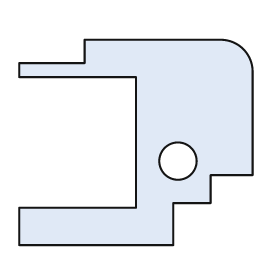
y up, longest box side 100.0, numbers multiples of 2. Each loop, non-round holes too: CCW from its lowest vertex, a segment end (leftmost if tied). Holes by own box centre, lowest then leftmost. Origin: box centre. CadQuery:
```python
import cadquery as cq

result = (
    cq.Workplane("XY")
    .moveTo(-50.0, -44.0)
    .lineTo(16.0, -44.0)
    .lineTo(16.0, -26.0)
    .lineTo(32.0, -26.0)
    .lineTo(32.0, -14.0)
    .lineTo(50.0, -14.0)
    .lineTo(50.0, 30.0)
    .threePointArc((46.0, 40.0), (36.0, 44.0))
    .lineTo(-22.0, 44.0)
    .lineTo(-22.0, 34.0)
    .lineTo(-50.0, 34.0)
    .lineTo(-50.0, 28.0)
    .lineTo(0.0, 28.0)
    .lineTo(0.0, -28.0)
    .lineTo(-50.0, -28.0)
    .close()
    .moveTo(18.0, -8.0)
    .circle(8.0)
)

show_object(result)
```